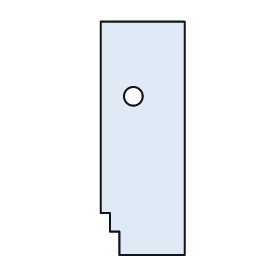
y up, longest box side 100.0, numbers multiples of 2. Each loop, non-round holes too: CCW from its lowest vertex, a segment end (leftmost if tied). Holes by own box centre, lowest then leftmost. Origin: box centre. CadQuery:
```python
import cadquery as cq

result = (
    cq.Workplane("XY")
    .moveTo(-10.0, -50.0)
    .lineTo(18.0, -50.0)
    .lineTo(18.0, 50.0)
    .lineTo(-18.0, 50.0)
    .lineTo(-18.0, -32.0)
    .lineTo(-14.0, -32.0)
    .lineTo(-14.0, -40.0)
    .lineTo(-10.0, -40.0)
    .close()
    .moveTo(-4.0, 18.0)
    .circle(4.0)
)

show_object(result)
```